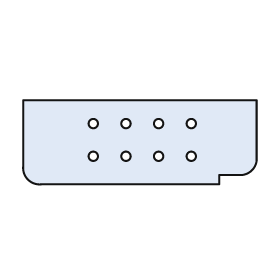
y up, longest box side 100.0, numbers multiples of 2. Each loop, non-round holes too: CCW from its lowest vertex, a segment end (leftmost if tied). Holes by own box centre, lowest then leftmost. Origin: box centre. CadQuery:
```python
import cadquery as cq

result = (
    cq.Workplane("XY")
    .moveTo(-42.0, -18.0)
    .lineTo(34.0, -18.0)
    .lineTo(34.0, -14.0)
    .lineTo(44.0, -14.0)
    .threePointArc((48.0, -12.0), (50.0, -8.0))
    .lineTo(50.0, 18.0)
    .lineTo(-50.0, 18.0)
    .lineTo(-50.0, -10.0)
    .threePointArc((-48.0, -16.0), (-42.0, -18.0))
    .close()
    .moveTo(-20.0, -6.0)
    .circle(2.0)
    .moveTo(-6.0, -6.0)
    .circle(2.0)
    .moveTo(8.0, -6.0)
    .circle(2.0)
    .moveTo(22.0, -6.0)
    .circle(2.0)
    .moveTo(-20.0, 8.0)
    .circle(2.0)
    .moveTo(-6.0, 8.0)
    .circle(2.0)
    .moveTo(8.0, 8.0)
    .circle(2.0)
    .moveTo(22.0, 8.0)
    .circle(2.0)
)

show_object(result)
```